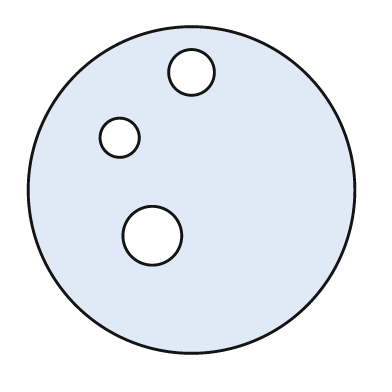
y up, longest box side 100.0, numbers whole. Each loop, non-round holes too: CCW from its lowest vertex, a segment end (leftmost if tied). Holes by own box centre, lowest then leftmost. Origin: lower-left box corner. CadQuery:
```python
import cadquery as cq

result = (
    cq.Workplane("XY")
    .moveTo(50.0, 50.0)
    .circle(50.0)
    .moveTo(38.0, 36.0)
    .circle(9.0)
    .moveTo(28.0, 66.0)
    .circle(6.0)
    .moveTo(50.0, 86.0)
    .circle(7.0)
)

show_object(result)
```